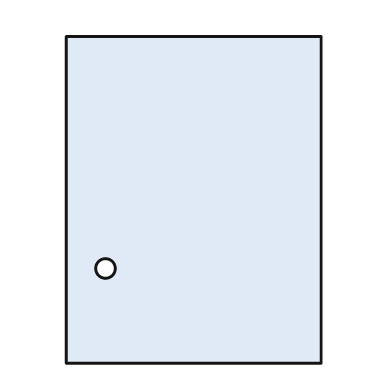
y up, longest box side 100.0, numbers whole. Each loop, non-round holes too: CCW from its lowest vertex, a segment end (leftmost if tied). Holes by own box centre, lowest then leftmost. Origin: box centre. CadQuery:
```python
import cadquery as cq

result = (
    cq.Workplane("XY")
    .moveTo(-39.0, -50.0)
    .lineTo(39.0, -50.0)
    .lineTo(39.0, 50.0)
    .lineTo(-39.0, 50.0)
    .close()
    .moveTo(-27.0, -21.0)
    .circle(3.0)
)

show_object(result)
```